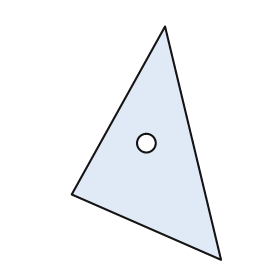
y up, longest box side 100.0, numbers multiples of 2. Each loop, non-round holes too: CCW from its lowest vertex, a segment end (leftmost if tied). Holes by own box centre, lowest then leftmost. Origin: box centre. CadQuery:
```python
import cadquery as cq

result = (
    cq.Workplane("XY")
    .moveTo(32.0, -50.0)
    .lineTo(8.0, 50.0)
    .lineTo(-32.0, -22.0)
    .close()
    .moveTo(0.0, 0.0)
    .circle(4.0)
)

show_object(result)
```